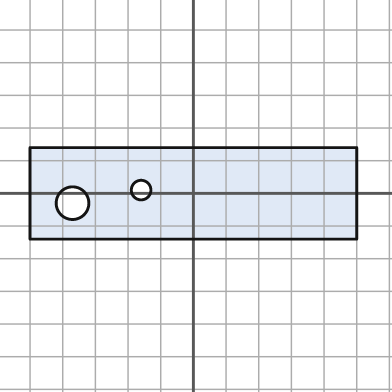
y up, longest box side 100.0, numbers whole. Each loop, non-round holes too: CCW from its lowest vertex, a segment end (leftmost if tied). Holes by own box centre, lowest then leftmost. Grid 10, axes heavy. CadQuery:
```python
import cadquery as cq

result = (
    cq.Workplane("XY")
    .moveTo(-50.0, -14.0)
    .lineTo(50.0, -14.0)
    .lineTo(50.0, 14.0)
    .lineTo(-50.0, 14.0)
    .close()
    .moveTo(-37.0, -3.0)
    .circle(5.0)
    .moveTo(-16.0, 1.0)
    .circle(3.0)
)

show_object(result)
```